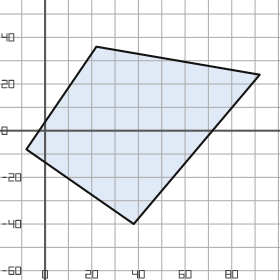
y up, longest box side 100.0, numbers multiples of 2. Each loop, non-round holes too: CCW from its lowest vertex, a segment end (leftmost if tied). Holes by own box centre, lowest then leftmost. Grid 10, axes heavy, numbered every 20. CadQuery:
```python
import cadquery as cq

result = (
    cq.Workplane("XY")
    .moveTo(38.0, -40.0)
    .lineTo(92.0, 24.0)
    .lineTo(22.0, 36.0)
    .lineTo(-8.0, -8.0)
    .close()
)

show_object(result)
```